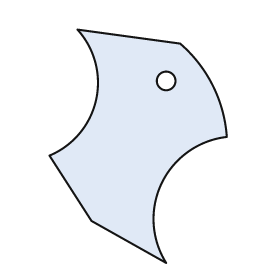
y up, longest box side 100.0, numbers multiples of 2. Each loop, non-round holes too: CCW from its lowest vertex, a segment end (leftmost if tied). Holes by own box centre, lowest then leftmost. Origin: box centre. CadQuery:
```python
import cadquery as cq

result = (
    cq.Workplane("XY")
    .moveTo(12.0, -50.0)
    .threePointArc((10.0, -16.0), (38.0, 4.0))
    .threePointArc((32.0, 26.0), (18.0, 44.0))
    .lineTo(-26.0, 50.0)
    .threePointArc((-18.0, 20.0), (-38.0, -4.0))
    .lineTo(-20.0, -32.0)
    .close()
    .moveTo(12.0, 28.0)
    .circle(4.0)
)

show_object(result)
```